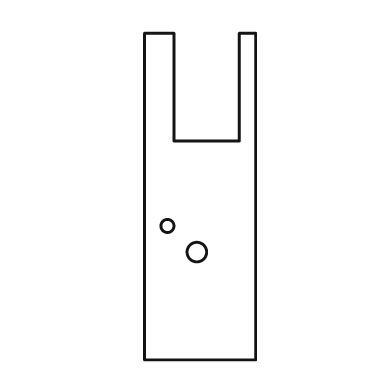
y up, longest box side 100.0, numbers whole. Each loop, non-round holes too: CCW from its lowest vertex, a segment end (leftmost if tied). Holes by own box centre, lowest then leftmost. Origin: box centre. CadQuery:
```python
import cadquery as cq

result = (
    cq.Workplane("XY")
    .moveTo(-17.0, -50.0)
    .lineTo(17.0, -50.0)
    .lineTo(17.0, 50.0)
    .lineTo(12.0, 50.0)
    .lineTo(12.0, 17.0)
    .lineTo(-8.0, 17.0)
    .lineTo(-8.0, 50.0)
    .lineTo(-17.0, 50.0)
    .close()
    .moveTo(-1.0, -17.0)
    .circle(3.0)
    .moveTo(-10.0, -9.0)
    .circle(2.0)
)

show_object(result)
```